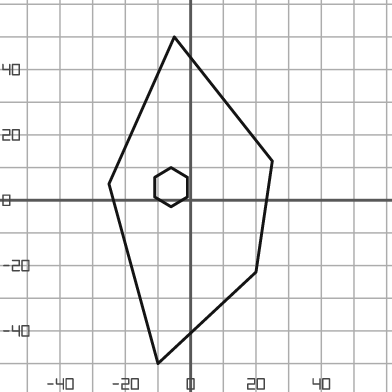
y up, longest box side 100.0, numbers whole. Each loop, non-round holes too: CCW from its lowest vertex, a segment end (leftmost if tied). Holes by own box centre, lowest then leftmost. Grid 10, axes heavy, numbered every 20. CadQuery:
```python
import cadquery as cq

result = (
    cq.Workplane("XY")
    .moveTo(-10.0, -50.0)
    .lineTo(20.0, -22.0)
    .lineTo(25.0, 12.0)
    .lineTo(-5.0, 50.0)
    .lineTo(-25.0, 5.0)
    .close()
    .moveTo(-6.0, -2.0)
    .lineTo(-1.0, 1.0)
    .lineTo(-1.0, 7.0)
    .lineTo(-6.0, 10.0)
    .lineTo(-11.0, 7.0)
    .lineTo(-11.0, 1.0)
    .close()
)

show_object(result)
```